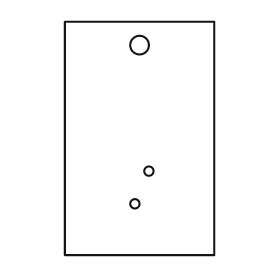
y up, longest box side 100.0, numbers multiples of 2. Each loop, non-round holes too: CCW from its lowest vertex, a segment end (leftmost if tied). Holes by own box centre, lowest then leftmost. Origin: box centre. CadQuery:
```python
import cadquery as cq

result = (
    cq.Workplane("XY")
    .moveTo(-32.0, -50.0)
    .lineTo(32.0, -50.0)
    .lineTo(32.0, 50.0)
    .lineTo(-32.0, 50.0)
    .close()
    .moveTo(-2.0, -28.0)
    .circle(2.0)
    .moveTo(4.0, -14.0)
    .circle(2.0)
    .moveTo(0.0, 40.0)
    .circle(4.0)
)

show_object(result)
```